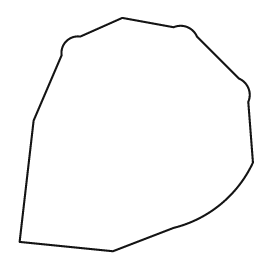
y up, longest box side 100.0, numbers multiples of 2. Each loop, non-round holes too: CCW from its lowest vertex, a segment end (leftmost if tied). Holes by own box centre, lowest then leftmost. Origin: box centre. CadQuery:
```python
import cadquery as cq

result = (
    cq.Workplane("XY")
    .moveTo(-10.0, -50.0)
    .lineTo(16.0, -40.0)
    .threePointArc((36.0, -30.0), (50.0, -12.0))
    .lineTo(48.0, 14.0)
    .threePointArc((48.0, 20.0), (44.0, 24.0))
    .lineTo(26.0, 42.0)
    .threePointArc((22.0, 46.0), (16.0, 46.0))
    .lineTo(-6.0, 50.0)
    .lineTo(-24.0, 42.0)
    .threePointArc((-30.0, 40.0), (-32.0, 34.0))
    .lineTo(-44.0, 6.0)
    .lineTo(-50.0, -46.0)
    .close()
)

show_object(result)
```